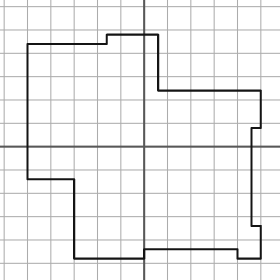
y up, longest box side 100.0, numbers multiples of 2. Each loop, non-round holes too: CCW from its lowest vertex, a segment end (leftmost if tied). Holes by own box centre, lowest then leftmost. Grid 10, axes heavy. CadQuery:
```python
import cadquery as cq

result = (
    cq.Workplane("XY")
    .moveTo(-30.0, -48.0)
    .lineTo(0.0, -48.0)
    .lineTo(0.0, -44.0)
    .lineTo(40.0, -44.0)
    .lineTo(40.0, -48.0)
    .lineTo(50.0, -48.0)
    .lineTo(50.0, -34.0)
    .lineTo(46.0, -34.0)
    .lineTo(46.0, 8.0)
    .lineTo(50.0, 8.0)
    .lineTo(50.0, 24.0)
    .lineTo(6.0, 24.0)
    .lineTo(6.0, 48.0)
    .lineTo(-16.0, 48.0)
    .lineTo(-16.0, 44.0)
    .lineTo(-50.0, 44.0)
    .lineTo(-50.0, -14.0)
    .lineTo(-30.0, -14.0)
    .close()
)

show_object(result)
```